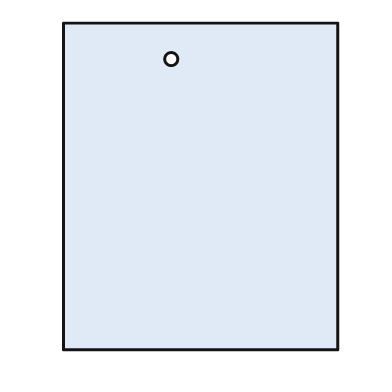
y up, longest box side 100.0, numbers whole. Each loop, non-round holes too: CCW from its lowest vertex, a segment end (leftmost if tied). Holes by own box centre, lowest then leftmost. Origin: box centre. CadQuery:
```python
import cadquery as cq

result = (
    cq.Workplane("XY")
    .moveTo(-42.0, -50.0)
    .lineTo(42.0, -50.0)
    .lineTo(42.0, 50.0)
    .lineTo(-42.0, 50.0)
    .close()
    .moveTo(-9.0, 39.0)
    .circle(2.0)
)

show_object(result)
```